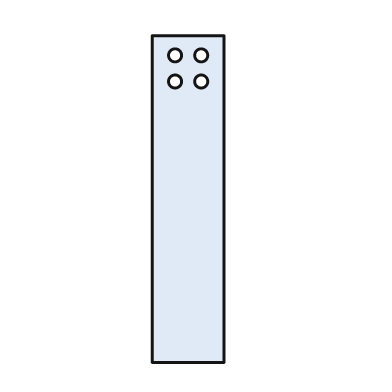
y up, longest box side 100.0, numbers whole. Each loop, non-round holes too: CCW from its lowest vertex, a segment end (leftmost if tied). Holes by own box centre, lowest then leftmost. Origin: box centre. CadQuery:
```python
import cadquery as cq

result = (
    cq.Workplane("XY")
    .moveTo(-11.0, -50.0)
    .lineTo(11.0, -50.0)
    .lineTo(11.0, 50.0)
    .lineTo(-11.0, 50.0)
    .close()
    .moveTo(-4.0, 36.0)
    .circle(2.0)
    .moveTo(4.0, 36.0)
    .circle(2.0)
    .moveTo(-4.0, 44.0)
    .circle(2.0)
    .moveTo(4.0, 44.0)
    .circle(2.0)
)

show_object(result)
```